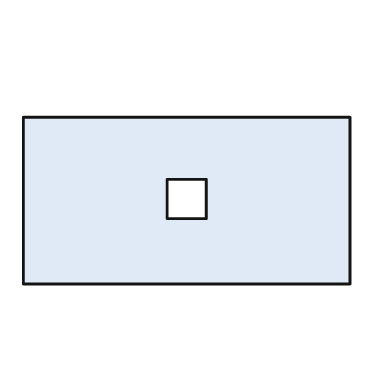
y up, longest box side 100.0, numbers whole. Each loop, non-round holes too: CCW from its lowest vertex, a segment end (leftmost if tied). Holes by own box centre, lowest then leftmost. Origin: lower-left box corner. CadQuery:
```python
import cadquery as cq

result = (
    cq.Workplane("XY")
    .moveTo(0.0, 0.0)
    .lineTo(100.0, 0.0)
    .lineTo(100.0, 51.0)
    .lineTo(0.0, 51.0)
    .close()
    .moveTo(44.0, 20.0)
    .lineTo(56.0, 20.0)
    .lineTo(56.0, 32.0)
    .lineTo(44.0, 32.0)
    .close()
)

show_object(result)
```